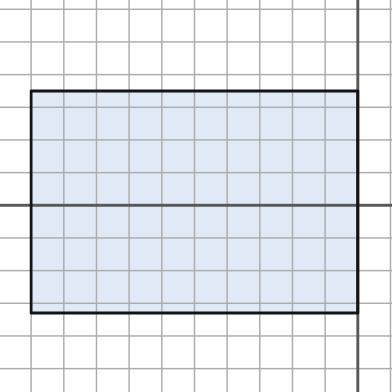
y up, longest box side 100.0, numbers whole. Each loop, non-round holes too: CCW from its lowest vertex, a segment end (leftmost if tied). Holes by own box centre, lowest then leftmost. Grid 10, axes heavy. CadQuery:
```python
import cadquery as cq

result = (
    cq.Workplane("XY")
    .moveTo(-100.0, -33.0)
    .lineTo(0.0, -33.0)
    .lineTo(0.0, 35.0)
    .lineTo(-100.0, 35.0)
    .close()
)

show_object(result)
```